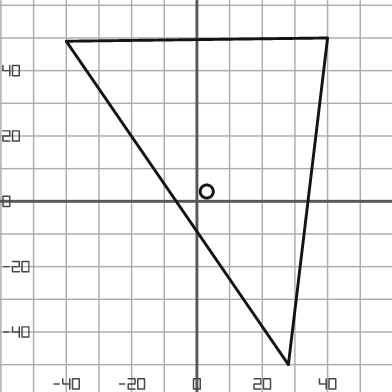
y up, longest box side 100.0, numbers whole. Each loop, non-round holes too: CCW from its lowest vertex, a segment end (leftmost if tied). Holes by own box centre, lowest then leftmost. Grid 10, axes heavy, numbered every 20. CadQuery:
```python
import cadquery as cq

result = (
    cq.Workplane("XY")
    .moveTo(28.0, -50.0)
    .lineTo(40.0, 50.0)
    .lineTo(-40.0, 49.0)
    .close()
    .moveTo(3.0, 3.0)
    .circle(2.0)
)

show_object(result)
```